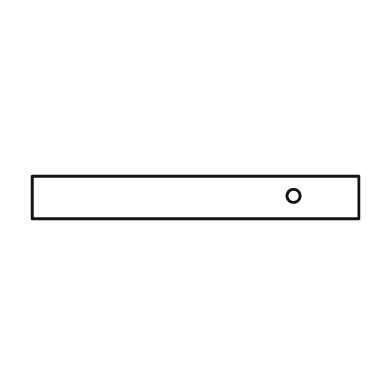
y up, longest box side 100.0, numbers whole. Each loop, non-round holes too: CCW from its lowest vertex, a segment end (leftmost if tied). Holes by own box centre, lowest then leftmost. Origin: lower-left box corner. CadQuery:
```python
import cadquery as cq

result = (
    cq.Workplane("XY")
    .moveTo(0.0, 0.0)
    .lineTo(100.0, 0.0)
    .lineTo(100.0, 13.0)
    .lineTo(0.0, 13.0)
    .close()
    .moveTo(80.0, 7.0)
    .circle(2.0)
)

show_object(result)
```